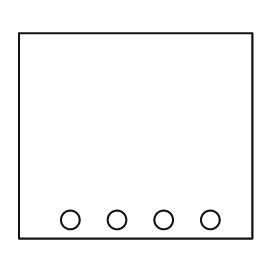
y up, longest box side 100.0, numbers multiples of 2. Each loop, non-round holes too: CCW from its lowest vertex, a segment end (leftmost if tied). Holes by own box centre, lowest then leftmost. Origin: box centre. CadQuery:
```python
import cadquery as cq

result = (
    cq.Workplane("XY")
    .moveTo(-50.0, -44.0)
    .lineTo(50.0, -44.0)
    .lineTo(50.0, 44.0)
    .lineTo(-50.0, 44.0)
    .close()
    .moveTo(-28.0, -36.0)
    .circle(4.0)
    .moveTo(-8.0, -36.0)
    .circle(4.0)
    .moveTo(12.0, -36.0)
    .circle(4.0)
    .moveTo(32.0, -36.0)
    .circle(4.0)
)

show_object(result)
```